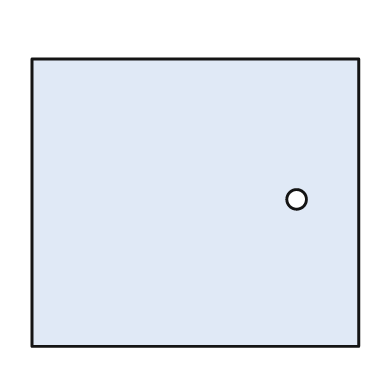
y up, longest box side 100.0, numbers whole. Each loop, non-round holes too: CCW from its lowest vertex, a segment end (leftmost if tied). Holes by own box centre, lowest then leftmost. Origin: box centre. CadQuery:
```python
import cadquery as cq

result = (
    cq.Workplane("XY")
    .moveTo(-50.0, -44.0)
    .lineTo(50.0, -44.0)
    .lineTo(50.0, 44.0)
    .lineTo(-50.0, 44.0)
    .close()
    .moveTo(31.0, 1.0)
    .circle(3.0)
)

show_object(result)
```